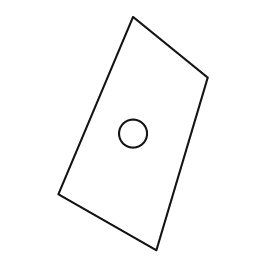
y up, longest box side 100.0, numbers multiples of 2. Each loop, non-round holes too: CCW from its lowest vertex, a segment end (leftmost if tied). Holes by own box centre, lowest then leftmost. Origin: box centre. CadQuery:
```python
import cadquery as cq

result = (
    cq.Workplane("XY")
    .moveTo(10.0, -50.0)
    .lineTo(32.0, 24.0)
    .lineTo(0.0, 50.0)
    .lineTo(-32.0, -26.0)
    .close()
    .moveTo(0.0, 0.0)
    .circle(6.0)
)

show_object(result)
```